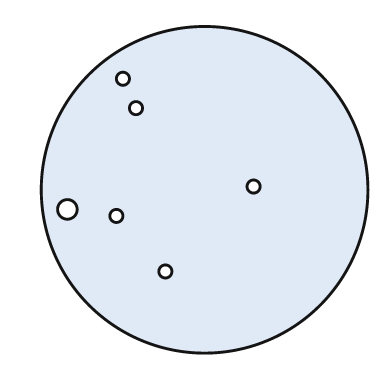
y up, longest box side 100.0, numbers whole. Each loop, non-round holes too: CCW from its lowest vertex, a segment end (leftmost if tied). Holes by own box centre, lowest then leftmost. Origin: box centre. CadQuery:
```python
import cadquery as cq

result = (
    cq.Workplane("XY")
    .moveTo(0.0, 0.0)
    .circle(50.0)
    .moveTo(-12.0, -25.0)
    .circle(2.0)
    .moveTo(-27.0, -8.0)
    .circle(2.0)
    .moveTo(-42.0, -6.0)
    .circle(3.0)
    .moveTo(15.0, 1.0)
    .circle(2.0)
    .moveTo(-21.0, 25.0)
    .circle(2.0)
    .moveTo(-25.0, 34.0)
    .circle(2.0)
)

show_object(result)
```